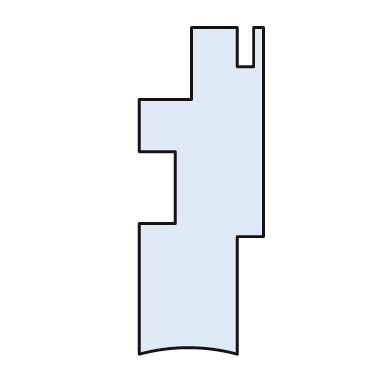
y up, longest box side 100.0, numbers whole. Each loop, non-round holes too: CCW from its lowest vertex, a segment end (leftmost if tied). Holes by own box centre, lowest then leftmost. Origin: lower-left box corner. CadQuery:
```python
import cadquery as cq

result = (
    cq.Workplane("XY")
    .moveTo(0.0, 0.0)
    .threePointArc((15.0, 2.0), (30.0, 0.0))
    .lineTo(30.0, 36.0)
    .lineTo(38.0, 36.0)
    .lineTo(38.0, 100.0)
    .lineTo(35.0, 100.0)
    .lineTo(35.0, 88.0)
    .lineTo(30.0, 88.0)
    .lineTo(30.0, 100.0)
    .lineTo(16.0, 100.0)
    .lineTo(16.0, 78.0)
    .lineTo(0.0, 78.0)
    .lineTo(0.0, 62.0)
    .lineTo(11.0, 62.0)
    .lineTo(11.0, 40.0)
    .lineTo(0.0, 40.0)
    .close()
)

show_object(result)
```